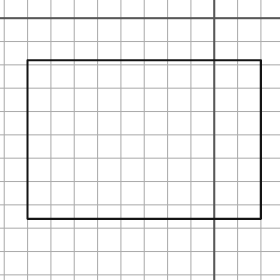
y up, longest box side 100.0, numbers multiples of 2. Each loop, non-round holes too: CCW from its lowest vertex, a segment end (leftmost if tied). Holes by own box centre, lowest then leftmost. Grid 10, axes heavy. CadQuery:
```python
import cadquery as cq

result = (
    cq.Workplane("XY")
    .moveTo(-80.0, -86.0)
    .lineTo(20.0, -86.0)
    .lineTo(20.0, -18.0)
    .lineTo(-80.0, -18.0)
    .close()
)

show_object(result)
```